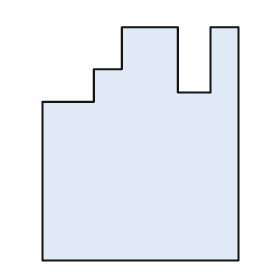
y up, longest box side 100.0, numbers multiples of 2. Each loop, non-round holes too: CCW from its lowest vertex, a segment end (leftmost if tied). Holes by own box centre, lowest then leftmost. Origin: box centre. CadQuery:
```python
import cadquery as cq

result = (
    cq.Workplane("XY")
    .moveTo(-42.0, -50.0)
    .lineTo(42.0, -50.0)
    .lineTo(42.0, 50.0)
    .lineTo(30.0, 50.0)
    .lineTo(30.0, 22.0)
    .lineTo(16.0, 22.0)
    .lineTo(16.0, 50.0)
    .lineTo(-8.0, 50.0)
    .lineTo(-8.0, 32.0)
    .lineTo(-20.0, 32.0)
    .lineTo(-20.0, 18.0)
    .lineTo(-42.0, 18.0)
    .close()
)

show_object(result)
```